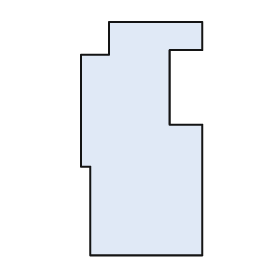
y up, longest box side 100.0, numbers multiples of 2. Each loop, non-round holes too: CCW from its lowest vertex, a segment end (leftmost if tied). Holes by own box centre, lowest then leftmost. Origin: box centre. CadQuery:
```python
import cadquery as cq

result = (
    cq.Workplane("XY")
    .moveTo(-22.0, -50.0)
    .lineTo(26.0, -50.0)
    .lineTo(26.0, 6.0)
    .lineTo(12.0, 6.0)
    .lineTo(12.0, 38.0)
    .lineTo(26.0, 38.0)
    .lineTo(26.0, 50.0)
    .lineTo(-14.0, 50.0)
    .lineTo(-14.0, 36.0)
    .lineTo(-26.0, 36.0)
    .lineTo(-26.0, -12.0)
    .lineTo(-22.0, -12.0)
    .close()
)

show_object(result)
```